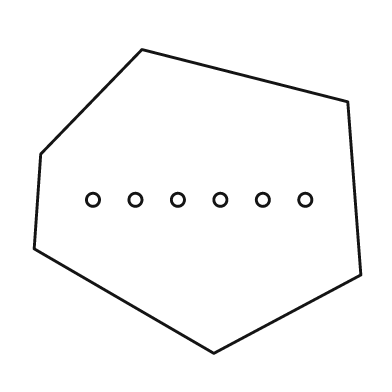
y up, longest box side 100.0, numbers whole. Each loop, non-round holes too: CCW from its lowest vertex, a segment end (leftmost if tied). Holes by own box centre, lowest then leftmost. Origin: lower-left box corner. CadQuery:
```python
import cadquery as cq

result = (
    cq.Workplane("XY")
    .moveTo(55.0, 0.0)
    .lineTo(100.0, 24.0)
    .lineTo(96.0, 77.0)
    .lineTo(33.0, 93.0)
    .lineTo(2.0, 61.0)
    .lineTo(0.0, 32.0)
    .close()
    .moveTo(18.0, 47.0)
    .circle(2.0)
    .moveTo(31.0, 47.0)
    .circle(2.0)
    .moveTo(44.0, 47.0)
    .circle(2.0)
    .moveTo(57.0, 47.0)
    .circle(2.0)
    .moveTo(70.0, 47.0)
    .circle(2.0)
    .moveTo(83.0, 47.0)
    .circle(2.0)
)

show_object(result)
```